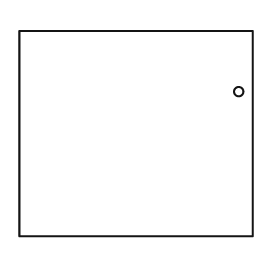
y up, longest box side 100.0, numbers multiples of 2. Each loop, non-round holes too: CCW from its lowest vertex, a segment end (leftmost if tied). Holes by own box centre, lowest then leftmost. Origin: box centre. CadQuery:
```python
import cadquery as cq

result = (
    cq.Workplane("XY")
    .moveTo(-50.0, -44.0)
    .lineTo(50.0, -44.0)
    .lineTo(50.0, 44.0)
    .lineTo(-50.0, 44.0)
    .close()
    .moveTo(44.0, 18.0)
    .circle(2.0)
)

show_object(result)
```